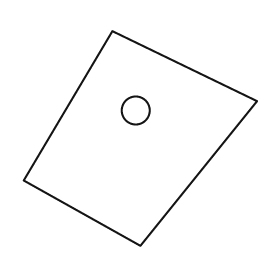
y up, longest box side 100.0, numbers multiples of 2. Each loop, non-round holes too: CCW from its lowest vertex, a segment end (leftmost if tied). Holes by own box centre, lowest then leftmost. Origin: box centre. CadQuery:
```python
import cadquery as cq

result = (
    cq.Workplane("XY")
    .moveTo(0.0, -46.0)
    .lineTo(50.0, 16.0)
    .lineTo(-12.0, 46.0)
    .lineTo(-50.0, -18.0)
    .close()
    .moveTo(-2.0, 12.0)
    .circle(6.0)
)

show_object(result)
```